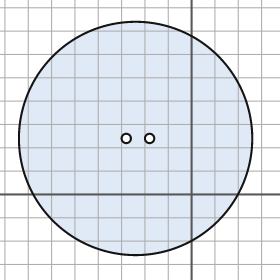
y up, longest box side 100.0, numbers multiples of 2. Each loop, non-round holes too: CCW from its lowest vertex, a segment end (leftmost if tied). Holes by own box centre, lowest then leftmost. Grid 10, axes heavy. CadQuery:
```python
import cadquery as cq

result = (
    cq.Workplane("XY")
    .moveTo(-24.0, 24.0)
    .circle(50.0)
    .moveTo(-28.0, 24.0)
    .circle(2.0)
    .moveTo(-18.0, 24.0)
    .circle(2.0)
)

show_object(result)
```